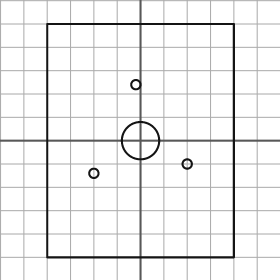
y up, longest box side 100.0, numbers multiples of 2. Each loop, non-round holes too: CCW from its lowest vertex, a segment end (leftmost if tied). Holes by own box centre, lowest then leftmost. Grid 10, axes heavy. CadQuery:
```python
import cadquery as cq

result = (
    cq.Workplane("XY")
    .moveTo(-40.0, -50.0)
    .lineTo(40.0, -50.0)
    .lineTo(40.0, 50.0)
    .lineTo(-40.0, 50.0)
    .close()
    .moveTo(-20.0, -14.0)
    .circle(2.0)
    .moveTo(20.0, -10.0)
    .circle(2.0)
    .moveTo(0.0, 0.0)
    .circle(8.0)
    .moveTo(-2.0, 24.0)
    .circle(2.0)
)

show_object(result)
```